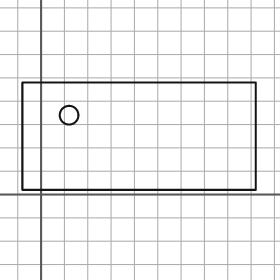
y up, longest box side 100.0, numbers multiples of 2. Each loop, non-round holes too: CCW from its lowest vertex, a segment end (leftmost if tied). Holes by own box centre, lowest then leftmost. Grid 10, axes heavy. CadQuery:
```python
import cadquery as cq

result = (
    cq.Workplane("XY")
    .moveTo(-8.0, 2.0)
    .lineTo(92.0, 2.0)
    .lineTo(92.0, 48.0)
    .lineTo(-8.0, 48.0)
    .close()
    .moveTo(12.0, 34.0)
    .circle(4.0)
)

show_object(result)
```